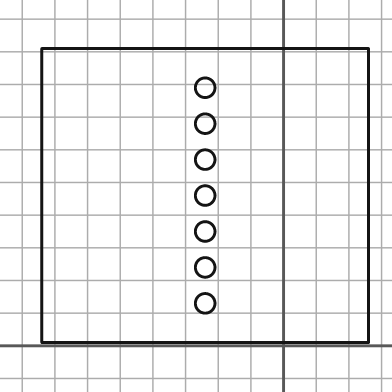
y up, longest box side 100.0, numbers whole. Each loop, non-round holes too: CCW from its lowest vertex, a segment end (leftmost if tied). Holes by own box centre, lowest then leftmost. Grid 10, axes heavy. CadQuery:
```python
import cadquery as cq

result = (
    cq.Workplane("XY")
    .moveTo(-74.0, 1.0)
    .lineTo(26.0, 1.0)
    .lineTo(26.0, 91.0)
    .lineTo(-74.0, 91.0)
    .close()
    .moveTo(-24.0, 13.0)
    .circle(3.0)
    .moveTo(-24.0, 24.0)
    .circle(3.0)
    .moveTo(-24.0, 35.0)
    .circle(3.0)
    .moveTo(-24.0, 46.0)
    .circle(3.0)
    .moveTo(-24.0, 57.0)
    .circle(3.0)
    .moveTo(-24.0, 68.0)
    .circle(3.0)
    .moveTo(-24.0, 79.0)
    .circle(3.0)
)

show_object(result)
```